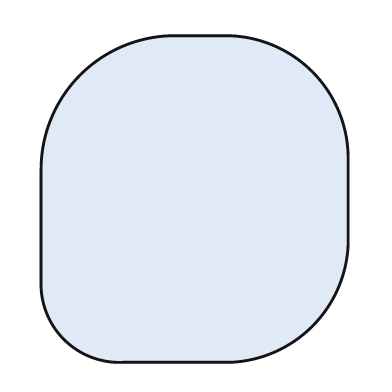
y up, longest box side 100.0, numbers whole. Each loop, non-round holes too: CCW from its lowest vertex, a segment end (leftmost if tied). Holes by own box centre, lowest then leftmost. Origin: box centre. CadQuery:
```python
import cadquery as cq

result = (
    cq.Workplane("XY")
    .moveTo(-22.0, -50.0)
    .lineTo(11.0, -50.0)
    .threePointArc((36.0, -39.0), (47.0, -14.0))
    .lineTo(47.0, 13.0)
    .threePointArc((36.0, 39.0), (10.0, 50.0))
    .lineTo(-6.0, 50.0)
    .threePointArc((-35.0, 38.0), (-47.0, 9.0))
    .lineTo(-47.0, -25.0)
    .threePointArc((-40.0, -43.0), (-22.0, -50.0))
    .close()
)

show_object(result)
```